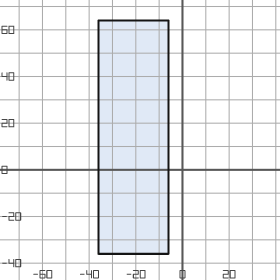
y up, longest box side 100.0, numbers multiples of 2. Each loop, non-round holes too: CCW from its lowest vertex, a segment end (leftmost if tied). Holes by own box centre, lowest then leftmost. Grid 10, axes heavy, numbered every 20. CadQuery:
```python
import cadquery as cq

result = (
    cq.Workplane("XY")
    .moveTo(-36.0, -36.0)
    .lineTo(-6.0, -36.0)
    .lineTo(-6.0, 64.0)
    .lineTo(-36.0, 64.0)
    .close()
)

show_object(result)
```